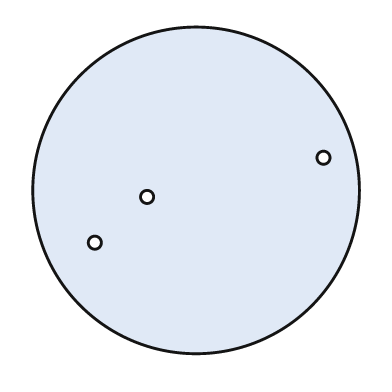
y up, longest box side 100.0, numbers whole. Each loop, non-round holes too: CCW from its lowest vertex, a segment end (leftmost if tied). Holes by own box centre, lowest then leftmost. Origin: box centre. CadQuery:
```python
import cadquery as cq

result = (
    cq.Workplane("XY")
    .moveTo(0.0, 0.0)
    .circle(50.0)
    .moveTo(-31.0, -16.0)
    .circle(2.0)
    .moveTo(-15.0, -2.0)
    .circle(2.0)
    .moveTo(39.0, 10.0)
    .circle(2.0)
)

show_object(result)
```